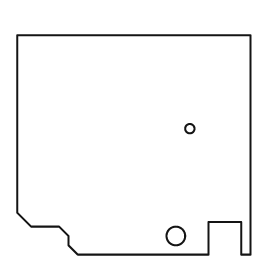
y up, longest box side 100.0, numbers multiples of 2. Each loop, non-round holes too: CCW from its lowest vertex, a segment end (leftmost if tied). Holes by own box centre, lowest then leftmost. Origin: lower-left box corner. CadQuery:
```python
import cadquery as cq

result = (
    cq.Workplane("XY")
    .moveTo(26.0, 0.0)
    .lineTo(82.0, 0.0)
    .lineTo(82.0, 14.0)
    .lineTo(96.0, 14.0)
    .lineTo(96.0, 0.0)
    .lineTo(100.0, 0.0)
    .lineTo(100.0, 94.0)
    .lineTo(0.0, 94.0)
    .lineTo(0.0, 18.0)
    .lineTo(6.0, 12.0)
    .lineTo(18.0, 12.0)
    .lineTo(22.0, 8.0)
    .lineTo(22.0, 4.0)
    .close()
    .moveTo(68.0, 8.0)
    .circle(4.0)
    .moveTo(74.0, 54.0)
    .circle(2.0)
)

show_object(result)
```